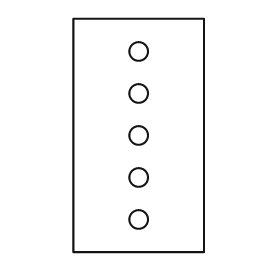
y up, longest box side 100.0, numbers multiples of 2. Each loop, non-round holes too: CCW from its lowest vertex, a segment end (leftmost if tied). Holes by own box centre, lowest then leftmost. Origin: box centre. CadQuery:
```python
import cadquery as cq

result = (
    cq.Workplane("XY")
    .moveTo(-28.0, -50.0)
    .lineTo(28.0, -50.0)
    .lineTo(28.0, 50.0)
    .lineTo(-28.0, 50.0)
    .close()
    .moveTo(0.0, -36.0)
    .circle(4.0)
    .moveTo(0.0, -18.0)
    .circle(4.0)
    .moveTo(0.0, 0.0)
    .circle(4.0)
    .moveTo(0.0, 18.0)
    .circle(4.0)
    .moveTo(0.0, 36.0)
    .circle(4.0)
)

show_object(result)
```